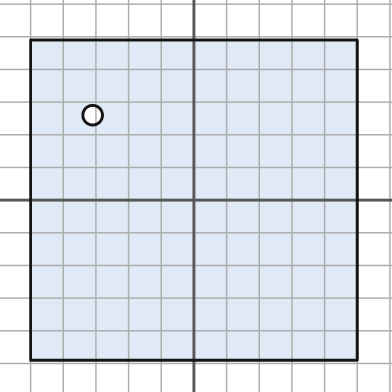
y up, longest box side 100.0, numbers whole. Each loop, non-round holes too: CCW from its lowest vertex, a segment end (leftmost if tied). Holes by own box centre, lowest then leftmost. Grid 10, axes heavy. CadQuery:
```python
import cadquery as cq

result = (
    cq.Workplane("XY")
    .moveTo(-50.0, -49.0)
    .lineTo(50.0, -49.0)
    .lineTo(50.0, 49.0)
    .lineTo(-50.0, 49.0)
    .close()
    .moveTo(-31.0, 26.0)
    .circle(3.0)
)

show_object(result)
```